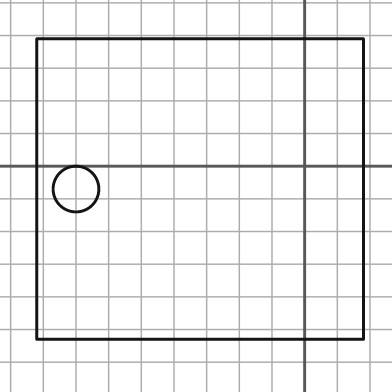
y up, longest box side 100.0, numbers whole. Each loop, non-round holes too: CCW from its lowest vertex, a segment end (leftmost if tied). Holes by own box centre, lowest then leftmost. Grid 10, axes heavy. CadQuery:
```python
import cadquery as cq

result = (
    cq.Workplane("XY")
    .moveTo(-82.0, -53.0)
    .lineTo(18.0, -53.0)
    .lineTo(18.0, 39.0)
    .lineTo(-82.0, 39.0)
    .close()
    .moveTo(-70.0, -7.0)
    .circle(7.0)
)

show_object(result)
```